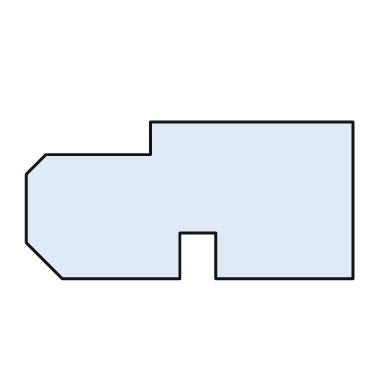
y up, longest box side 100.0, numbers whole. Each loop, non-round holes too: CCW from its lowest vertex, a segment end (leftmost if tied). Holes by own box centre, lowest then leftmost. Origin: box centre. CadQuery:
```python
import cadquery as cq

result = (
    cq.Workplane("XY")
    .moveTo(-39.0, -24.0)
    .lineTo(-3.0, -24.0)
    .lineTo(-3.0, -10.0)
    .lineTo(8.0, -10.0)
    .lineTo(8.0, -24.0)
    .lineTo(50.0, -24.0)
    .lineTo(50.0, 24.0)
    .lineTo(-12.0, 24.0)
    .lineTo(-12.0, 14.0)
    .lineTo(-44.0, 14.0)
    .lineTo(-50.0, 8.0)
    .lineTo(-50.0, -13.0)
    .close()
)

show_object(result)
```